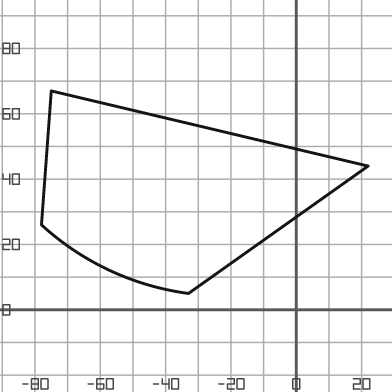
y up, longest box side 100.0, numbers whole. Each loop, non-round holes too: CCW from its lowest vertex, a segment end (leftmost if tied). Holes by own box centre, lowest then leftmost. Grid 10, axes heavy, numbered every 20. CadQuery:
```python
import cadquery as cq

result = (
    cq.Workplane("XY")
    .moveTo(-33.0, 5.0)
    .lineTo(22.0, 44.0)
    .lineTo(-75.0, 67.0)
    .lineTo(-78.0, 26.0)
    .threePointArc((-57.0, 12.0), (-33.0, 5.0))
    .close()
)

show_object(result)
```